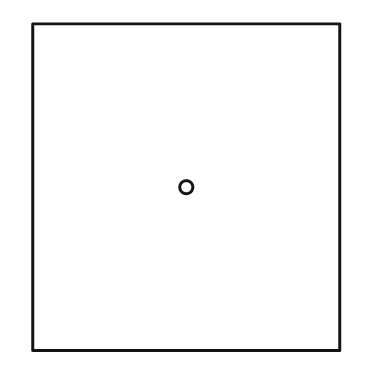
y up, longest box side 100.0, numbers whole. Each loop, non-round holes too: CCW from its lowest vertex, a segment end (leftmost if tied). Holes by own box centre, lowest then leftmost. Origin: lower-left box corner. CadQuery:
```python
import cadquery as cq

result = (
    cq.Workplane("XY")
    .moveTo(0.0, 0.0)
    .lineTo(94.0, 0.0)
    .lineTo(94.0, 100.0)
    .lineTo(0.0, 100.0)
    .close()
    .moveTo(47.0, 50.0)
    .circle(2.0)
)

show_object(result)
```